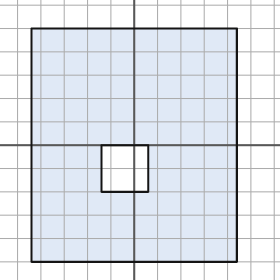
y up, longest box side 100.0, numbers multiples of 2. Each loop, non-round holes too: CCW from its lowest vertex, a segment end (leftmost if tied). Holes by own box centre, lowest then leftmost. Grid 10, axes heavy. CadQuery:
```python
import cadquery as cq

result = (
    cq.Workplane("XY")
    .moveTo(-44.0, -50.0)
    .lineTo(44.0, -50.0)
    .lineTo(44.0, 50.0)
    .lineTo(-44.0, 50.0)
    .close()
    .moveTo(-14.0, -20.0)
    .lineTo(6.0, -20.0)
    .lineTo(6.0, 0.0)
    .lineTo(-14.0, 0.0)
    .close()
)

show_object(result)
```